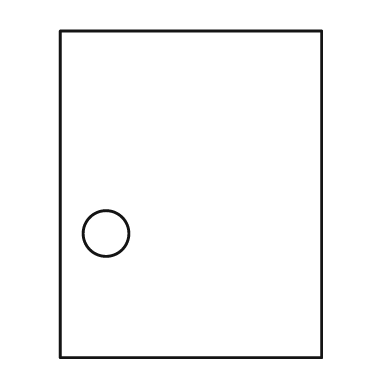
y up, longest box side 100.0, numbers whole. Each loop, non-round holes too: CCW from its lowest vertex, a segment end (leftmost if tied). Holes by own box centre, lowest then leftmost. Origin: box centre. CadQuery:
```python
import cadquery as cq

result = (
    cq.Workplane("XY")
    .moveTo(-40.0, -50.0)
    .lineTo(40.0, -50.0)
    .lineTo(40.0, 50.0)
    .lineTo(-40.0, 50.0)
    .close()
    .moveTo(-26.0, -12.0)
    .circle(7.0)
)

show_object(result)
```